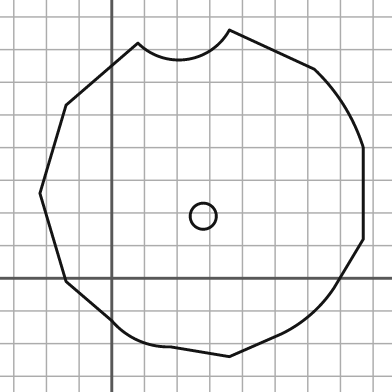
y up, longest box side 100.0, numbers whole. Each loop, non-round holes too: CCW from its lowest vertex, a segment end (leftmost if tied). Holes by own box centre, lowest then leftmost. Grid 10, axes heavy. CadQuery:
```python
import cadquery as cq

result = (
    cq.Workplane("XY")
    .moveTo(36.0, -24.0)
    .lineTo(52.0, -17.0)
    .threePointArc((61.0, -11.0), (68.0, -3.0))
    .lineTo(77.0, 12.0)
    .lineTo(77.0, 40.0)
    .threePointArc((71.0, 53.0), (62.0, 64.0))
    .lineTo(36.0, 76.0)
    .threePointArc((23.0, 67.0), (8.0, 72.0))
    .lineTo(-14.0, 53.0)
    .lineTo(-22.0, 26.0)
    .lineTo(-14.0, -1.0)
    .lineTo(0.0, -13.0)
    .threePointArc((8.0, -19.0), (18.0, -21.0))
    .close()
    .moveTo(28.0, 19.0)
    .circle(4.0)
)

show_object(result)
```